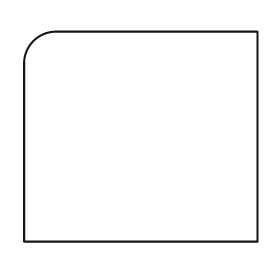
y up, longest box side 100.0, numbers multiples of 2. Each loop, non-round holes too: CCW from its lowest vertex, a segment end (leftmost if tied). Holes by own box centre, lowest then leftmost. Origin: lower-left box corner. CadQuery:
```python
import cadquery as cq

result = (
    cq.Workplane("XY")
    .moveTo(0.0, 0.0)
    .lineTo(100.0, 0.0)
    .lineTo(100.0, 90.0)
    .lineTo(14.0, 90.0)
    .threePointArc((4.0, 86.0), (0.0, 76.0))
    .close()
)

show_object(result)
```